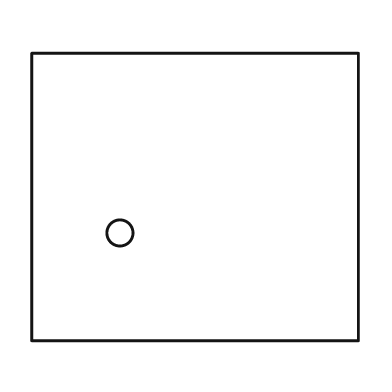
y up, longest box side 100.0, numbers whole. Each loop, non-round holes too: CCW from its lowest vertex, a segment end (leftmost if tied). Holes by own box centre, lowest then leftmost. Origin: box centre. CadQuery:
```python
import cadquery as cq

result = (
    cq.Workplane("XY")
    .moveTo(-50.0, -44.0)
    .lineTo(50.0, -44.0)
    .lineTo(50.0, 44.0)
    .lineTo(-50.0, 44.0)
    .close()
    .moveTo(-23.0, -11.0)
    .circle(4.0)
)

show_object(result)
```